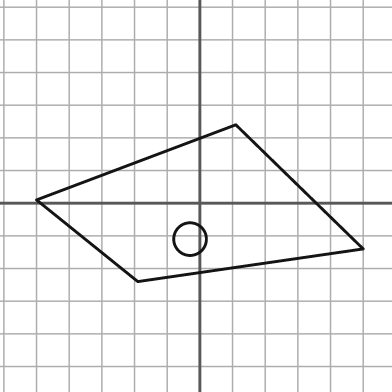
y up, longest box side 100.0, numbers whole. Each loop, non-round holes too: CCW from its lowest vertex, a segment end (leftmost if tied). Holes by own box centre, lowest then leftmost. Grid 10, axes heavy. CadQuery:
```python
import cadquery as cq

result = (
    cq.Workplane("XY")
    .moveTo(-19.0, -24.0)
    .lineTo(50.0, -14.0)
    .lineTo(11.0, 24.0)
    .lineTo(-50.0, 1.0)
    .close()
    .moveTo(-3.0, -11.0)
    .circle(5.0)
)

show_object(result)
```